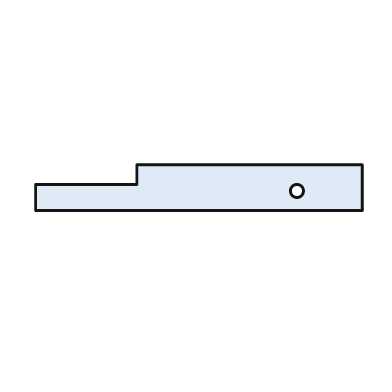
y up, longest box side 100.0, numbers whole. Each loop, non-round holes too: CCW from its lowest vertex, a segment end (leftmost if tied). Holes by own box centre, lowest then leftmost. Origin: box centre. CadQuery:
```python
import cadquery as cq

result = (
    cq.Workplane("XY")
    .moveTo(-50.0, -7.0)
    .lineTo(50.0, -7.0)
    .lineTo(50.0, 7.0)
    .lineTo(-19.0, 7.0)
    .lineTo(-19.0, 1.0)
    .lineTo(-50.0, 1.0)
    .close()
    .moveTo(30.0, -1.0)
    .circle(2.0)
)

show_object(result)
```